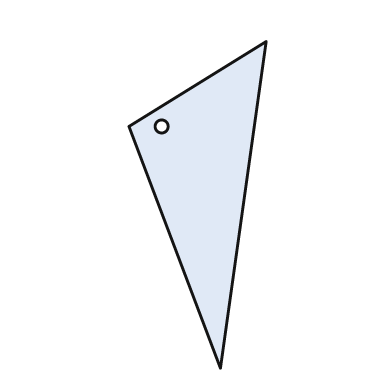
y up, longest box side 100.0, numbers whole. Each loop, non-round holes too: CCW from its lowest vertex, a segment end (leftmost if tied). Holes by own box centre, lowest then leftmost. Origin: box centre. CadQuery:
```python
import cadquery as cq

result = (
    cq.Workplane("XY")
    .moveTo(7.0, -50.0)
    .lineTo(21.0, 50.0)
    .lineTo(-21.0, 24.0)
    .close()
    .moveTo(-11.0, 24.0)
    .circle(2.0)
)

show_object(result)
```